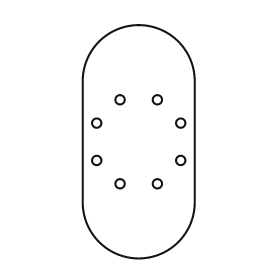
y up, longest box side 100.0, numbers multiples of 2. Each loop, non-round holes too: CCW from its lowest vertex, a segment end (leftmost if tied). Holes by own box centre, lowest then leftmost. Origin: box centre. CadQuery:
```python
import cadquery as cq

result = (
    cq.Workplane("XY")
    .moveTo(-24.0, -26.0)
    .threePointArc((0.0, -50.0), (24.0, -26.0))
    .lineTo(24.0, 26.0)
    .threePointArc((0.0, 50.0), (-24.0, 26.0))
    .close()
    .moveTo(-8.0, -18.0)
    .circle(2.0)
    .moveTo(8.0, -18.0)
    .circle(2.0)
    .moveTo(-18.0, -8.0)
    .circle(2.0)
    .moveTo(18.0, -8.0)
    .circle(2.0)
    .moveTo(-18.0, 8.0)
    .circle(2.0)
    .moveTo(18.0, 8.0)
    .circle(2.0)
    .moveTo(-8.0, 18.0)
    .circle(2.0)
    .moveTo(8.0, 18.0)
    .circle(2.0)
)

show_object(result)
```